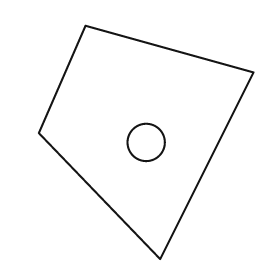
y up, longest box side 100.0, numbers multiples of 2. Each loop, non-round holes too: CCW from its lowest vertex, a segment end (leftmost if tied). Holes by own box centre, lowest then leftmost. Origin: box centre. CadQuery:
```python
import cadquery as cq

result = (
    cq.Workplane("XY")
    .moveTo(6.0, -50.0)
    .lineTo(46.0, 30.0)
    .lineTo(-26.0, 50.0)
    .lineTo(-46.0, 4.0)
    .close()
    .moveTo(0.0, 0.0)
    .circle(8.0)
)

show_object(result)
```